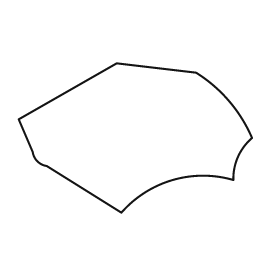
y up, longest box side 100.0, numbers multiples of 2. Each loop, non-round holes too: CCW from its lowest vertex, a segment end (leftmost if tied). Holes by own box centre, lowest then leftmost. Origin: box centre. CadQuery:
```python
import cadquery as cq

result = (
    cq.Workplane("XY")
    .moveTo(-6.0, -32.0)
    .threePointArc((16.0, -18.0), (42.0, -18.0))
    .threePointArc((44.0, -8.0), (50.0, 0.0))
    .threePointArc((40.0, 16.0), (26.0, 28.0))
    .lineTo(-8.0, 32.0)
    .lineTo(-50.0, 8.0)
    .lineTo(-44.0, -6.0)
    .threePointArc((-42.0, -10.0), (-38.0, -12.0))
    .close()
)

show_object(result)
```